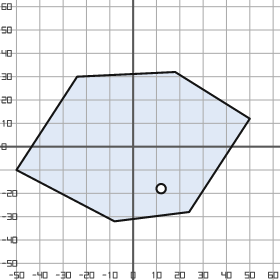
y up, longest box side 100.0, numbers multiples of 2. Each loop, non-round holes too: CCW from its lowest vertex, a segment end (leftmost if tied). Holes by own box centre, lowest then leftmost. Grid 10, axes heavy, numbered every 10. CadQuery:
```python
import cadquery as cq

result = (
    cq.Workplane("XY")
    .moveTo(-8.0, -32.0)
    .lineTo(24.0, -28.0)
    .lineTo(50.0, 12.0)
    .lineTo(18.0, 32.0)
    .lineTo(-24.0, 30.0)
    .lineTo(-50.0, -10.0)
    .close()
    .moveTo(12.0, -18.0)
    .circle(2.0)
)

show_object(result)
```